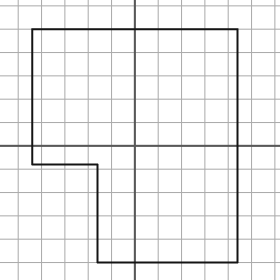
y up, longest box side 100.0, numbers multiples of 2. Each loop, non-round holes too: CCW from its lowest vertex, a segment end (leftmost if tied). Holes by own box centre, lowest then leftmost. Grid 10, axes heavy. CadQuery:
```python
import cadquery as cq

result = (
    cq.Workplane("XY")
    .moveTo(-16.0, -50.0)
    .lineTo(44.0, -50.0)
    .lineTo(44.0, 50.0)
    .lineTo(-44.0, 50.0)
    .lineTo(-44.0, -8.0)
    .lineTo(-16.0, -8.0)
    .close()
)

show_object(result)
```